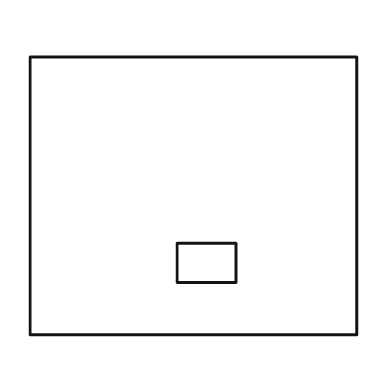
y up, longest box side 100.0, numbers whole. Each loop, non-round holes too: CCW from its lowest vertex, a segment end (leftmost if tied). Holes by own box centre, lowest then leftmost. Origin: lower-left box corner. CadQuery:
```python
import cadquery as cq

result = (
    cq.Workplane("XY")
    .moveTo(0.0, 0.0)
    .lineTo(100.0, 0.0)
    .lineTo(100.0, 85.0)
    .lineTo(0.0, 85.0)
    .close()
    .moveTo(45.0, 16.0)
    .lineTo(63.0, 16.0)
    .lineTo(63.0, 28.0)
    .lineTo(45.0, 28.0)
    .close()
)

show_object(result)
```